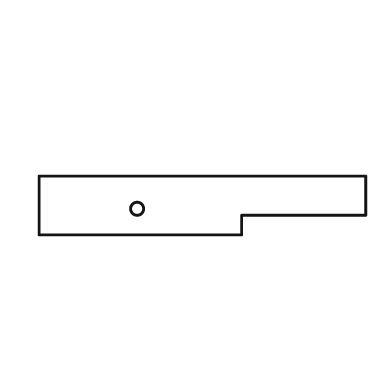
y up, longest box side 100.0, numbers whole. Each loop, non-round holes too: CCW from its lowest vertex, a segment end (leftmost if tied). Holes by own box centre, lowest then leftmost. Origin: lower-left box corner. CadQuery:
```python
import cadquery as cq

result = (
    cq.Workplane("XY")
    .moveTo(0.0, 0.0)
    .lineTo(62.0, 0.0)
    .lineTo(62.0, 6.0)
    .lineTo(100.0, 6.0)
    .lineTo(100.0, 18.0)
    .lineTo(0.0, 18.0)
    .close()
    .moveTo(30.0, 8.0)
    .circle(2.0)
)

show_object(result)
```